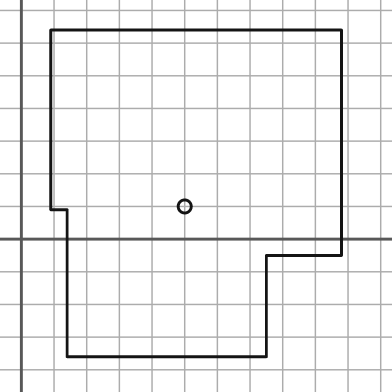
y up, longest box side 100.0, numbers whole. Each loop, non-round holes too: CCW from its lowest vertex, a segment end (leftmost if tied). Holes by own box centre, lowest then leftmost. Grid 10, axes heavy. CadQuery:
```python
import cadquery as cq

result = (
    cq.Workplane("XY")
    .moveTo(14.0, -36.0)
    .lineTo(75.0, -36.0)
    .lineTo(75.0, -5.0)
    .lineTo(98.0, -5.0)
    .lineTo(98.0, 64.0)
    .lineTo(9.0, 64.0)
    .lineTo(9.0, 9.0)
    .lineTo(14.0, 9.0)
    .close()
    .moveTo(50.0, 10.0)
    .circle(2.0)
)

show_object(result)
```